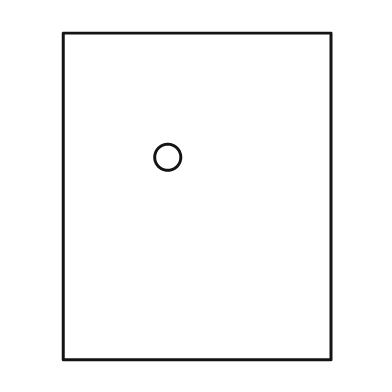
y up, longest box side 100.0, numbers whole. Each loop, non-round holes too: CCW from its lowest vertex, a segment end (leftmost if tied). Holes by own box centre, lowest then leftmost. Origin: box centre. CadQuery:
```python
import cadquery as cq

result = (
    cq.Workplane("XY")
    .moveTo(-41.0, -50.0)
    .lineTo(41.0, -50.0)
    .lineTo(41.0, 50.0)
    .lineTo(-41.0, 50.0)
    .close()
    .moveTo(-9.0, 12.0)
    .circle(4.0)
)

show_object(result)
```